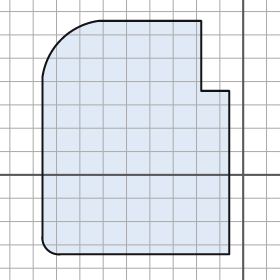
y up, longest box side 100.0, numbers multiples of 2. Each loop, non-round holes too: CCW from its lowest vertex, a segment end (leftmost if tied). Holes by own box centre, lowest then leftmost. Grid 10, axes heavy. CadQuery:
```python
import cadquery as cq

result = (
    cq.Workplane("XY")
    .moveTo(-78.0, -34.0)
    .lineTo(-6.0, -34.0)
    .lineTo(-6.0, 36.0)
    .lineTo(-18.0, 36.0)
    .lineTo(-18.0, 66.0)
    .lineTo(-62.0, 66.0)
    .threePointArc((-78.0, 58.0), (-86.0, 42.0))
    .lineTo(-86.0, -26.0)
    .threePointArc((-84.0, -32.0), (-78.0, -34.0))
    .close()
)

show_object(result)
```